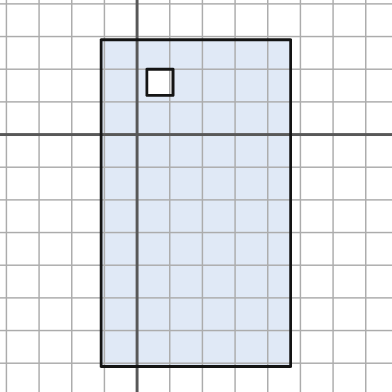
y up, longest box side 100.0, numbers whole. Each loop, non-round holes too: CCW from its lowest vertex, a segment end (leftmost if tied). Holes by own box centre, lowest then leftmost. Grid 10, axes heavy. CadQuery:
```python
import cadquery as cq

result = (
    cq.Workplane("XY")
    .moveTo(-11.0, -71.0)
    .lineTo(47.0, -71.0)
    .lineTo(47.0, 29.0)
    .lineTo(-11.0, 29.0)
    .close()
    .moveTo(3.0, 12.0)
    .lineTo(11.0, 12.0)
    .lineTo(11.0, 20.0)
    .lineTo(3.0, 20.0)
    .close()
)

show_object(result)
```